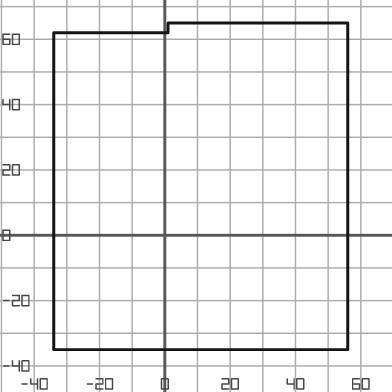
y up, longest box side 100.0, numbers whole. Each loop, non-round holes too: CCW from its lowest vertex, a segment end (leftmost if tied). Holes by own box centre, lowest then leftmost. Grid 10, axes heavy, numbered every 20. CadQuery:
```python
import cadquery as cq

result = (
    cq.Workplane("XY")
    .moveTo(-34.0, -35.0)
    .lineTo(56.0, -35.0)
    .lineTo(56.0, 65.0)
    .lineTo(1.0, 65.0)
    .lineTo(1.0, 62.0)
    .lineTo(-34.0, 62.0)
    .close()
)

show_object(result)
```